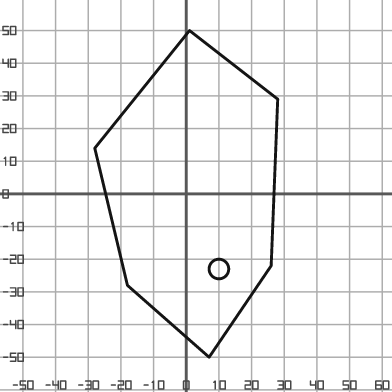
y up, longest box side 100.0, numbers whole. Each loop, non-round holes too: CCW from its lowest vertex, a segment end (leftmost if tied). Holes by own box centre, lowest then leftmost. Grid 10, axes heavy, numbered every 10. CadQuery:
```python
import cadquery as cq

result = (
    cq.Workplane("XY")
    .moveTo(7.0, -50.0)
    .lineTo(26.0, -22.0)
    .lineTo(28.0, 29.0)
    .lineTo(1.0, 50.0)
    .lineTo(-28.0, 14.0)
    .lineTo(-18.0, -28.0)
    .close()
    .moveTo(10.0, -23.0)
    .circle(3.0)
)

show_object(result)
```